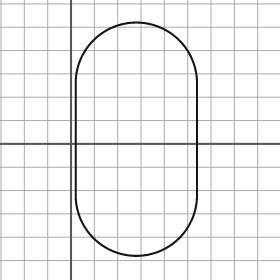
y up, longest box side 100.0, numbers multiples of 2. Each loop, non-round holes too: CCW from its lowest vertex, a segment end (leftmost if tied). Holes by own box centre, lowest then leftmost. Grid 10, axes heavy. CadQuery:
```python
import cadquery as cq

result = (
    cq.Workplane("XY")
    .moveTo(2.0, -22.0)
    .threePointArc((28.0, -48.0), (54.0, -22.0))
    .lineTo(54.0, 26.0)
    .threePointArc((28.0, 52.0), (2.0, 26.0))
    .close()
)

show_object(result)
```